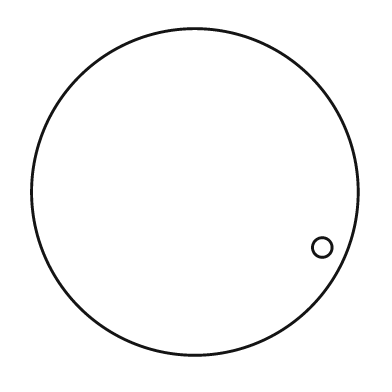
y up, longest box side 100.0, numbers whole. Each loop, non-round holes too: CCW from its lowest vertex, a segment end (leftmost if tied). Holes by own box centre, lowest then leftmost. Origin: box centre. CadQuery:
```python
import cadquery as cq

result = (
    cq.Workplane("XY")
    .moveTo(0.0, 0.0)
    .circle(50.0)
    .moveTo(39.0, -17.0)
    .circle(3.0)
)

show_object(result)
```